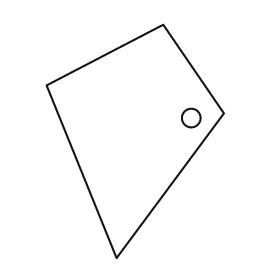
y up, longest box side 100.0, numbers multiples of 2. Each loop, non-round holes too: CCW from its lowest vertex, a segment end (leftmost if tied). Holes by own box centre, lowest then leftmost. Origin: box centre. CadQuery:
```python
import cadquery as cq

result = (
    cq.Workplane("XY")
    .moveTo(-8.0, -50.0)
    .lineTo(38.0, 12.0)
    .lineTo(12.0, 50.0)
    .lineTo(-38.0, 24.0)
    .close()
    .moveTo(24.0, 10.0)
    .circle(4.0)
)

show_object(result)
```